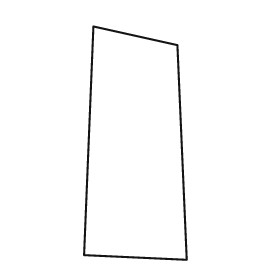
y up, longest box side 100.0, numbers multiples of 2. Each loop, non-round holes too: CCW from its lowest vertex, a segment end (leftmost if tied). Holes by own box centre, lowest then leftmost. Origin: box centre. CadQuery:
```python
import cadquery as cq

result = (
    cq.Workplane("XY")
    .moveTo(22.0, -50.0)
    .lineTo(18.0, 42.0)
    .lineTo(-18.0, 50.0)
    .lineTo(-22.0, -48.0)
    .close()
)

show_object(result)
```